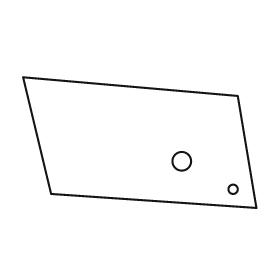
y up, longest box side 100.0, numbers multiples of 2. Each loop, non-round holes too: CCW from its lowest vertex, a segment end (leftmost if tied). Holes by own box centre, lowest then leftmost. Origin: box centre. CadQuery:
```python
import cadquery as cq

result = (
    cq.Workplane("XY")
    .moveTo(50.0, -28.0)
    .lineTo(42.0, 20.0)
    .lineTo(-50.0, 28.0)
    .lineTo(-38.0, -22.0)
    .close()
    .moveTo(40.0, -20.0)
    .circle(2.0)
    .moveTo(18.0, -8.0)
    .circle(4.0)
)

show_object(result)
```